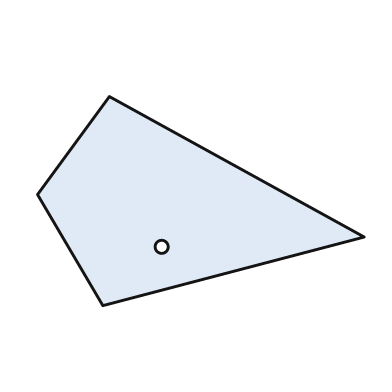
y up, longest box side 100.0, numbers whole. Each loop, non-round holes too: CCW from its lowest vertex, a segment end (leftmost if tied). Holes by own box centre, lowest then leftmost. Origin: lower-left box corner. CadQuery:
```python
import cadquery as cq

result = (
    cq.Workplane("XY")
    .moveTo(20.0, 0.0)
    .lineTo(100.0, 21.0)
    .lineTo(22.0, 64.0)
    .lineTo(0.0, 34.0)
    .close()
    .moveTo(38.0, 18.0)
    .circle(2.0)
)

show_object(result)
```